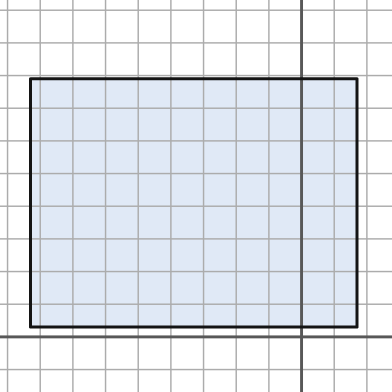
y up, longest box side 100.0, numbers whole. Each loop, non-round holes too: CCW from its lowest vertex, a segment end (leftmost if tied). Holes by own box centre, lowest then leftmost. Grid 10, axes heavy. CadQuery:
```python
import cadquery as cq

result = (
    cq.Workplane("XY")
    .moveTo(-83.0, 3.0)
    .lineTo(17.0, 3.0)
    .lineTo(17.0, 79.0)
    .lineTo(-83.0, 79.0)
    .close()
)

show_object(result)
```